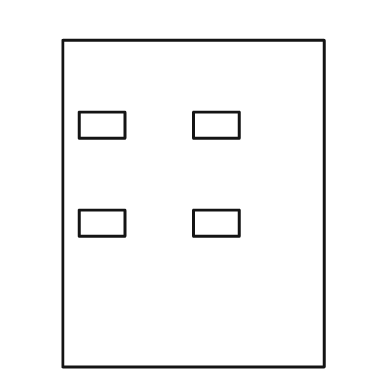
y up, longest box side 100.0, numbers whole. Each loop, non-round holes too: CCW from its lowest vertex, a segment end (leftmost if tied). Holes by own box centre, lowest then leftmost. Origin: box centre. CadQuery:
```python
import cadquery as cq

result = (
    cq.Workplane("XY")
    .moveTo(-40.0, -50.0)
    .lineTo(40.0, -50.0)
    .lineTo(40.0, 50.0)
    .lineTo(-40.0, 50.0)
    .close()
    .moveTo(-35.0, -10.0)
    .lineTo(-21.0, -10.0)
    .lineTo(-21.0, -2.0)
    .lineTo(-35.0, -2.0)
    .close()
    .moveTo(0.0, -10.0)
    .lineTo(14.0, -10.0)
    .lineTo(14.0, -2.0)
    .lineTo(0.0, -2.0)
    .close()
    .moveTo(-35.0, 20.0)
    .lineTo(-21.0, 20.0)
    .lineTo(-21.0, 28.0)
    .lineTo(-35.0, 28.0)
    .close()
    .moveTo(0.0, 20.0)
    .lineTo(14.0, 20.0)
    .lineTo(14.0, 28.0)
    .lineTo(0.0, 28.0)
    .close()
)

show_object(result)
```